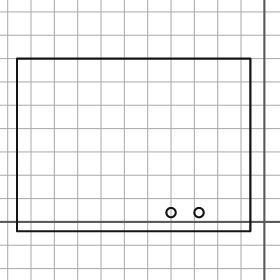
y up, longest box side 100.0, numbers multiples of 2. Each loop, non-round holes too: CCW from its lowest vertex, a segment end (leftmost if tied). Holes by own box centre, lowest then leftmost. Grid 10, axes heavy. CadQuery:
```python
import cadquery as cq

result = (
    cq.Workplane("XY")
    .moveTo(-106.0, -4.0)
    .lineTo(-6.0, -4.0)
    .lineTo(-6.0, 70.0)
    .lineTo(-106.0, 70.0)
    .close()
    .moveTo(-40.0, 4.0)
    .circle(2.0)
    .moveTo(-28.0, 4.0)
    .circle(2.0)
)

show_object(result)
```